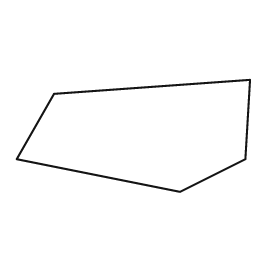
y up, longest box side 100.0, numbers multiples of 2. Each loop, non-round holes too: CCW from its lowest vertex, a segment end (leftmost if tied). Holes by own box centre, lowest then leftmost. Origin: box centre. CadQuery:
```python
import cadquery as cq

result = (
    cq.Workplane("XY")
    .moveTo(20.0, -24.0)
    .lineTo(48.0, -10.0)
    .lineTo(50.0, 24.0)
    .lineTo(-34.0, 18.0)
    .lineTo(-50.0, -10.0)
    .close()
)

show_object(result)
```